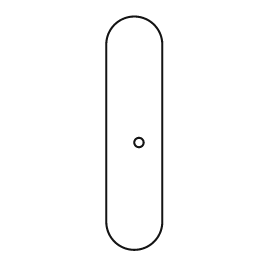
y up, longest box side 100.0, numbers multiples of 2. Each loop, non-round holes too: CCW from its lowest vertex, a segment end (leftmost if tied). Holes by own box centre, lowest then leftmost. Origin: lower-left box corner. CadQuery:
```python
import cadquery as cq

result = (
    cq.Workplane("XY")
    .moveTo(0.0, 12.0)
    .threePointArc((12.0, 0.0), (24.0, 12.0))
    .lineTo(24.0, 88.0)
    .threePointArc((12.0, 100.0), (0.0, 88.0))
    .close()
    .moveTo(14.0, 46.0)
    .circle(2.0)
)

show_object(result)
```